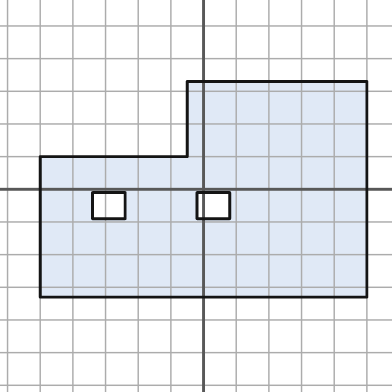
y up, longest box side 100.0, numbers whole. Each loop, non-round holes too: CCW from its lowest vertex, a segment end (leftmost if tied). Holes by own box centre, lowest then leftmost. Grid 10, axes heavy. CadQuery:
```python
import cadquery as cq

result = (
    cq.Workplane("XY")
    .moveTo(-50.0, -33.0)
    .lineTo(50.0, -33.0)
    .lineTo(50.0, 33.0)
    .lineTo(-5.0, 33.0)
    .lineTo(-5.0, 10.0)
    .lineTo(-50.0, 10.0)
    .close()
    .moveTo(-34.0, -9.0)
    .lineTo(-24.0, -9.0)
    .lineTo(-24.0, -1.0)
    .lineTo(-34.0, -1.0)
    .close()
    .moveTo(-2.0, -9.0)
    .lineTo(8.0, -9.0)
    .lineTo(8.0, -1.0)
    .lineTo(-2.0, -1.0)
    .close()
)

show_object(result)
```